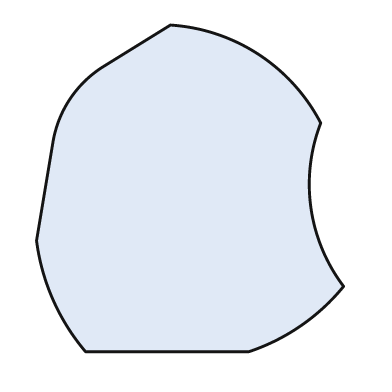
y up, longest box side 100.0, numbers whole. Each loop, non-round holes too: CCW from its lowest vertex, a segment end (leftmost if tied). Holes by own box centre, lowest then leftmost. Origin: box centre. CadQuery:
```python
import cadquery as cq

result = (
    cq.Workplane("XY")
    .moveTo(-32.0, -50.0)
    .lineTo(18.0, -50.0)
    .threePointArc((34.0, -42.0), (47.0, -30.0))
    .threePointArc((37.0, -6.0), (40.0, 20.0))
    .threePointArc((21.0, 41.0), (-6.0, 50.0))
    .lineTo(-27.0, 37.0)
    .threePointArc((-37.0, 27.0), (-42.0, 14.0))
    .lineTo(-47.0, -16.0)
    .threePointArc((-42.0, -34.0), (-32.0, -50.0))
    .close()
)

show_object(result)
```